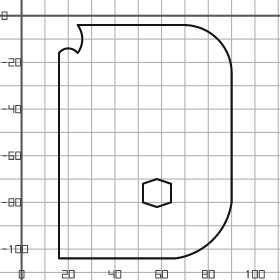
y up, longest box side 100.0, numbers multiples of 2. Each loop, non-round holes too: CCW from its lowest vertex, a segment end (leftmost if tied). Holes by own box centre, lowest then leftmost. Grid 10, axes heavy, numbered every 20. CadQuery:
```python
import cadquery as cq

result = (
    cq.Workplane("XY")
    .moveTo(16.0, -104.0)
    .lineTo(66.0, -104.0)
    .threePointArc((82.0, -96.0), (90.0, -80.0))
    .lineTo(90.0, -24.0)
    .threePointArc((84.0, -10.0), (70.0, -4.0))
    .lineTo(24.0, -4.0)
    .threePointArc((26.0, -10.0), (24.0, -16.0))
    .threePointArc((20.0, -14.0), (16.0, -16.0))
    .close()
    .moveTo(58.0, -82.0)
    .lineTo(64.0, -80.0)
    .lineTo(64.0, -72.0)
    .lineTo(58.0, -70.0)
    .lineTo(52.0, -72.0)
    .lineTo(52.0, -80.0)
    .close()
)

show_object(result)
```